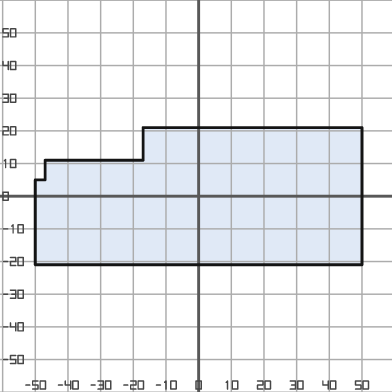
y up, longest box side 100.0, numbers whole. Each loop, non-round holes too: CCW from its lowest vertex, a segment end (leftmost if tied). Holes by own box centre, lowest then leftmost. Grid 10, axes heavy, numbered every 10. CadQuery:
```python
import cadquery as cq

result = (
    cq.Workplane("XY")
    .moveTo(-50.0, -21.0)
    .lineTo(50.0, -21.0)
    .lineTo(50.0, 21.0)
    .lineTo(-17.0, 21.0)
    .lineTo(-17.0, 11.0)
    .lineTo(-47.0, 11.0)
    .lineTo(-47.0, 5.0)
    .lineTo(-50.0, 5.0)
    .close()
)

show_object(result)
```